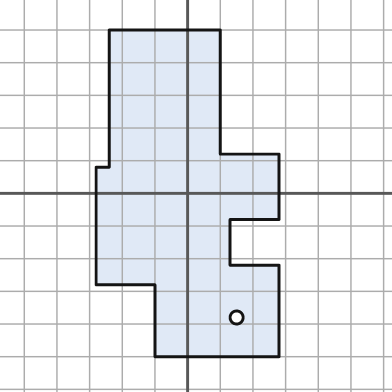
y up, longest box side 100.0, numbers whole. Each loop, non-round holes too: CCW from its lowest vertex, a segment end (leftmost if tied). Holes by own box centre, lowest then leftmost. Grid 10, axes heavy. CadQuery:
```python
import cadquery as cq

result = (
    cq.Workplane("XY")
    .moveTo(-10.0, -50.0)
    .lineTo(28.0, -50.0)
    .lineTo(28.0, -22.0)
    .lineTo(13.0, -22.0)
    .lineTo(13.0, -8.0)
    .lineTo(28.0, -8.0)
    .lineTo(28.0, 12.0)
    .lineTo(10.0, 12.0)
    .lineTo(10.0, 50.0)
    .lineTo(-24.0, 50.0)
    .lineTo(-24.0, 8.0)
    .lineTo(-28.0, 8.0)
    .lineTo(-28.0, -28.0)
    .lineTo(-10.0, -28.0)
    .close()
    .moveTo(15.0, -38.0)
    .circle(2.0)
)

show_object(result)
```